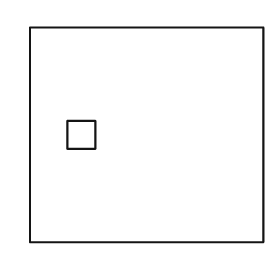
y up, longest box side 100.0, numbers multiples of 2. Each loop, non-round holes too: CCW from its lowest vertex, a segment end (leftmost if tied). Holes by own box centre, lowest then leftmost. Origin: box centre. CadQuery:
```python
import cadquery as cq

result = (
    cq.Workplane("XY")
    .moveTo(-50.0, -46.0)
    .lineTo(50.0, -46.0)
    .lineTo(50.0, 46.0)
    .lineTo(-50.0, 46.0)
    .close()
    .moveTo(-34.0, -6.0)
    .lineTo(-22.0, -6.0)
    .lineTo(-22.0, 6.0)
    .lineTo(-34.0, 6.0)
    .close()
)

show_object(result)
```